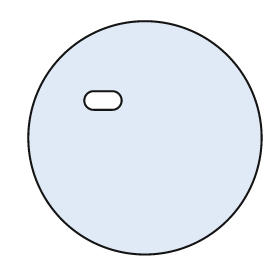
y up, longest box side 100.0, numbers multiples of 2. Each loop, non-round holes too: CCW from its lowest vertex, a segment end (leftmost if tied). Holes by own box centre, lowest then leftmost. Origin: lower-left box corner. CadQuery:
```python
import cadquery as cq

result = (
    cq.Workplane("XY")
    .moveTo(50.0, 50.0)
    .circle(50.0)
    .moveTo(28.0, 62.0)
    .lineTo(36.0, 62.0)
    .threePointArc((40.0, 66.0), (36.0, 70.0))
    .lineTo(28.0, 70.0)
    .threePointArc((24.0, 66.0), (28.0, 62.0))
    .close()
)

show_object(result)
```